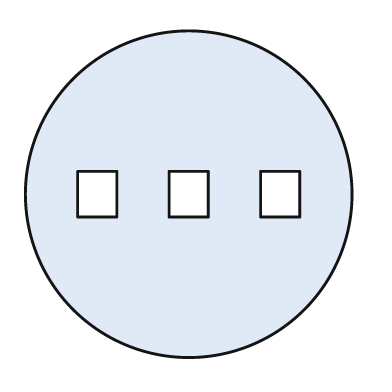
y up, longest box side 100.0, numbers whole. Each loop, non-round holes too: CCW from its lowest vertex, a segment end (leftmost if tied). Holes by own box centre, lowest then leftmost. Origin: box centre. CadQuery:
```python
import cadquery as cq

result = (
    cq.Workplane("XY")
    .moveTo(0.0, 0.0)
    .circle(50.0)
    .moveTo(-34.0, -7.0)
    .lineTo(-22.0, -7.0)
    .lineTo(-22.0, 7.0)
    .lineTo(-34.0, 7.0)
    .close()
    .moveTo(-6.0, -7.0)
    .lineTo(6.0, -7.0)
    .lineTo(6.0, 7.0)
    .lineTo(-6.0, 7.0)
    .close()
    .moveTo(22.0, -7.0)
    .lineTo(34.0, -7.0)
    .lineTo(34.0, 7.0)
    .lineTo(22.0, 7.0)
    .close()
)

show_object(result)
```